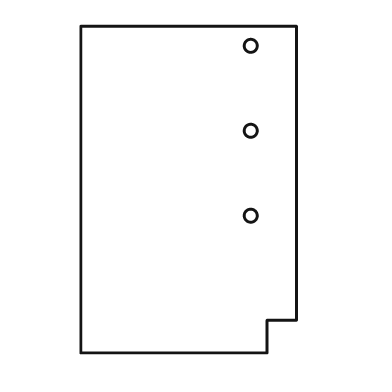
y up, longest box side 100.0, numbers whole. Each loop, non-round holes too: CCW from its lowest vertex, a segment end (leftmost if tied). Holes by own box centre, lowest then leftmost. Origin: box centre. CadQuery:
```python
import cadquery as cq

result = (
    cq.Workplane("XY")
    .moveTo(-33.0, -50.0)
    .lineTo(24.0, -50.0)
    .lineTo(24.0, -40.0)
    .lineTo(33.0, -40.0)
    .lineTo(33.0, 50.0)
    .lineTo(-33.0, 50.0)
    .close()
    .moveTo(19.0, -8.0)
    .circle(2.0)
    .moveTo(19.0, 18.0)
    .circle(2.0)
    .moveTo(19.0, 44.0)
    .circle(2.0)
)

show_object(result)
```